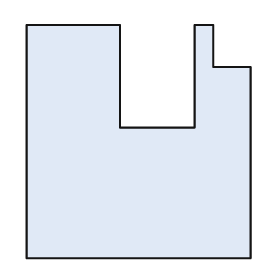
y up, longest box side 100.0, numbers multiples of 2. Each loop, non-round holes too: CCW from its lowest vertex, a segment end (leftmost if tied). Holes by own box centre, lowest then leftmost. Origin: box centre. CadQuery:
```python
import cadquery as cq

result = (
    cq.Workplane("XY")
    .moveTo(-48.0, -50.0)
    .lineTo(48.0, -50.0)
    .lineTo(48.0, 32.0)
    .lineTo(32.0, 32.0)
    .lineTo(32.0, 50.0)
    .lineTo(24.0, 50.0)
    .lineTo(24.0, 6.0)
    .lineTo(-8.0, 6.0)
    .lineTo(-8.0, 50.0)
    .lineTo(-48.0, 50.0)
    .close()
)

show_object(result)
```